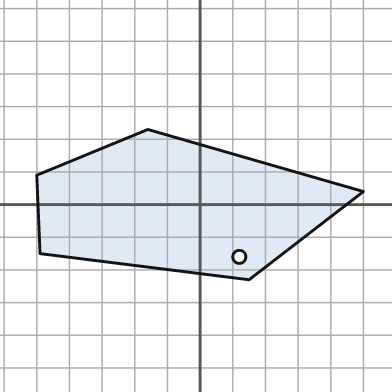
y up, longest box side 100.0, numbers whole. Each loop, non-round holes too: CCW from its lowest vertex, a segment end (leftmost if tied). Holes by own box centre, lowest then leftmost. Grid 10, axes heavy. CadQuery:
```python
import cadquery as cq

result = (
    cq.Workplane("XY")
    .moveTo(15.0, -23.0)
    .lineTo(50.0, 4.0)
    .lineTo(-16.0, 23.0)
    .lineTo(-50.0, 9.0)
    .lineTo(-49.0, -15.0)
    .close()
    .moveTo(12.0, -16.0)
    .circle(2.0)
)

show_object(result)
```